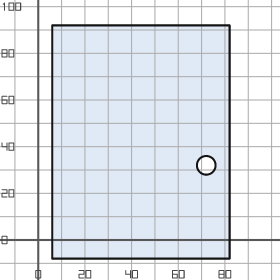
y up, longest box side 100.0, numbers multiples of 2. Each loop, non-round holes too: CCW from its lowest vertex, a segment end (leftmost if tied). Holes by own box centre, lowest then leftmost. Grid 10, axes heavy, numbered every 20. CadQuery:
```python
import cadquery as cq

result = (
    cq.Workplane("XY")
    .moveTo(6.0, -8.0)
    .lineTo(82.0, -8.0)
    .lineTo(82.0, 92.0)
    .lineTo(6.0, 92.0)
    .close()
    .moveTo(72.0, 32.0)
    .circle(4.0)
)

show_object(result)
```